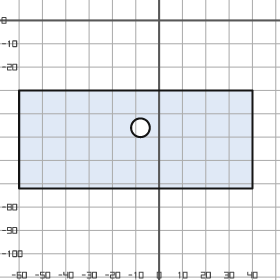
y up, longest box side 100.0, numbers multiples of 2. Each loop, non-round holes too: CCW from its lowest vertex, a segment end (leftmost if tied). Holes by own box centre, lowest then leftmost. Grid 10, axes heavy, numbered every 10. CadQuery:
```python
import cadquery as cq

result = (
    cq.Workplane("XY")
    .moveTo(-60.0, -72.0)
    .lineTo(40.0, -72.0)
    .lineTo(40.0, -30.0)
    .lineTo(-60.0, -30.0)
    .close()
    .moveTo(-8.0, -46.0)
    .circle(4.0)
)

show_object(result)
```